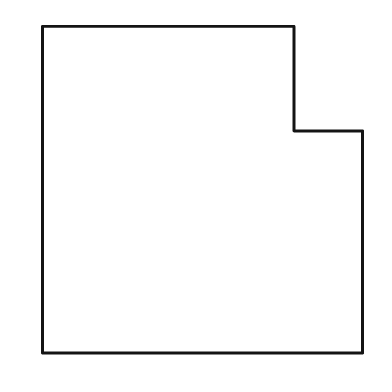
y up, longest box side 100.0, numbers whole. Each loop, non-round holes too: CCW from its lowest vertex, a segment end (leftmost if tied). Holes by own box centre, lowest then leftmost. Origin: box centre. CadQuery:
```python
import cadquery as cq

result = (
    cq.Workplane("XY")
    .moveTo(-49.0, -50.0)
    .lineTo(49.0, -50.0)
    .lineTo(49.0, 18.0)
    .lineTo(28.0, 18.0)
    .lineTo(28.0, 50.0)
    .lineTo(-49.0, 50.0)
    .close()
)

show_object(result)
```